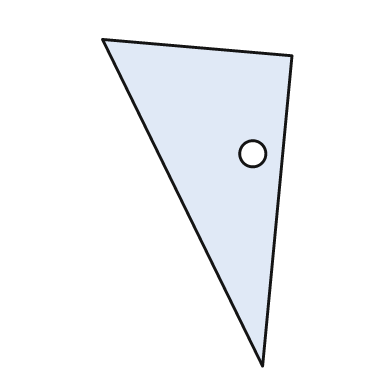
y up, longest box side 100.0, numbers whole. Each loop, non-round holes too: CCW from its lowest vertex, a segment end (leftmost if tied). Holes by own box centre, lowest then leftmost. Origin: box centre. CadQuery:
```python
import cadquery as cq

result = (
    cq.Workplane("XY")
    .moveTo(20.0, -50.0)
    .lineTo(29.0, 45.0)
    .lineTo(-29.0, 50.0)
    .close()
    .moveTo(17.0, 15.0)
    .circle(4.0)
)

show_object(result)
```